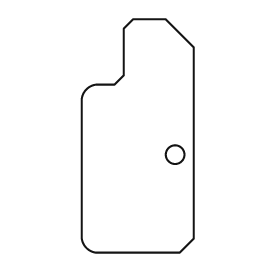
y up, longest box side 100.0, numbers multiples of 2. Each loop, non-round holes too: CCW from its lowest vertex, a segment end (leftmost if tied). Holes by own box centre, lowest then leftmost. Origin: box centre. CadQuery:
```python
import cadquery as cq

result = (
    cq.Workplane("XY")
    .moveTo(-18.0, -50.0)
    .lineTo(18.0, -50.0)
    .lineTo(24.0, -44.0)
    .lineTo(24.0, 38.0)
    .lineTo(12.0, 50.0)
    .lineTo(-2.0, 50.0)
    .lineTo(-6.0, 46.0)
    .lineTo(-6.0, 26.0)
    .lineTo(-10.0, 22.0)
    .lineTo(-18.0, 22.0)
    .threePointArc((-22.0, 20.0), (-24.0, 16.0))
    .lineTo(-24.0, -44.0)
    .threePointArc((-22.0, -48.0), (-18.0, -50.0))
    .close()
    .moveTo(16.0, -8.0)
    .circle(4.0)
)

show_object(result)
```